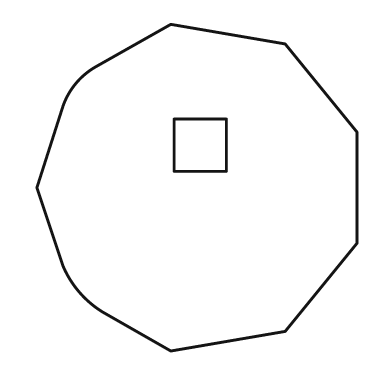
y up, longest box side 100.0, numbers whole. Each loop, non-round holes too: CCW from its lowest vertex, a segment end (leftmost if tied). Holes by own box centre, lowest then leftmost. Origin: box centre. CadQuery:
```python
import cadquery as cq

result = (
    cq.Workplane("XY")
    .moveTo(-8.0, -50.0)
    .lineTo(27.0, -44.0)
    .lineTo(49.0, -17.0)
    .lineTo(49.0, 17.0)
    .lineTo(27.0, 44.0)
    .lineTo(-8.0, 50.0)
    .lineTo(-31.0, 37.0)
    .threePointArc((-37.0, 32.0), (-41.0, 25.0))
    .lineTo(-49.0, 0.0)
    .lineTo(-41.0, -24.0)
    .threePointArc((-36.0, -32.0), (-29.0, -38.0))
    .close()
    .moveTo(-7.0, 5.0)
    .lineTo(9.0, 5.0)
    .lineTo(9.0, 21.0)
    .lineTo(-7.0, 21.0)
    .close()
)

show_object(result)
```